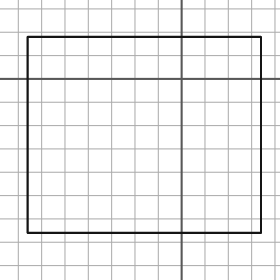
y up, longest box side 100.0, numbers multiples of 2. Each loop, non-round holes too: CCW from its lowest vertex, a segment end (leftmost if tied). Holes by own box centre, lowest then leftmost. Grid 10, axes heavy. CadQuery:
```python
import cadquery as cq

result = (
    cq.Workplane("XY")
    .moveTo(-66.0, -66.0)
    .lineTo(34.0, -66.0)
    .lineTo(34.0, 18.0)
    .lineTo(-66.0, 18.0)
    .close()
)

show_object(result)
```